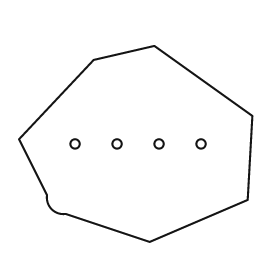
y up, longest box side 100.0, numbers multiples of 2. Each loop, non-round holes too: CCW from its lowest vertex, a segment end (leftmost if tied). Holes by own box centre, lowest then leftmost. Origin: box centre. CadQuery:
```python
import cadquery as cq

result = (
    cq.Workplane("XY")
    .moveTo(6.0, -42.0)
    .lineTo(48.0, -24.0)
    .lineTo(50.0, 12.0)
    .lineTo(8.0, 42.0)
    .lineTo(-18.0, 36.0)
    .lineTo(-50.0, 2.0)
    .lineTo(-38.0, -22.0)
    .threePointArc((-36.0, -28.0), (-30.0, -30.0))
    .close()
    .moveTo(-26.0, 0.0)
    .circle(2.0)
    .moveTo(-8.0, 0.0)
    .circle(2.0)
    .moveTo(10.0, 0.0)
    .circle(2.0)
    .moveTo(28.0, 0.0)
    .circle(2.0)
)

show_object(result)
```